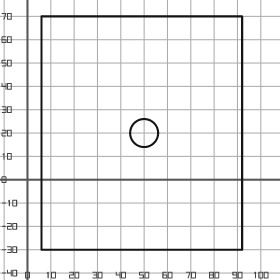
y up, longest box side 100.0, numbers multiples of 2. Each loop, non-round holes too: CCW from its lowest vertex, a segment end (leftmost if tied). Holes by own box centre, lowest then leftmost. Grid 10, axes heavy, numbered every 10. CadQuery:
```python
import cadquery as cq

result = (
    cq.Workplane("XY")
    .moveTo(6.0, -30.0)
    .lineTo(92.0, -30.0)
    .lineTo(92.0, 70.0)
    .lineTo(6.0, 70.0)
    .close()
    .moveTo(50.0, 20.0)
    .circle(6.0)
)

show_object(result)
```